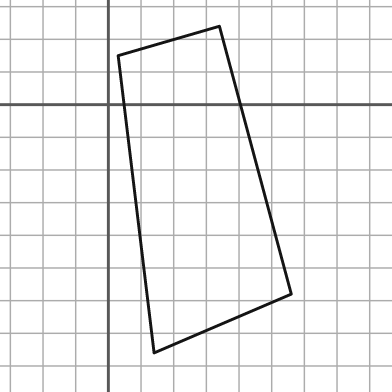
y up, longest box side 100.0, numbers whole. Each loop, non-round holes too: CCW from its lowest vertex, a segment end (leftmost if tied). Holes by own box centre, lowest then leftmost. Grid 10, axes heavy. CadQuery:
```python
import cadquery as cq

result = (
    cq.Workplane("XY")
    .moveTo(14.0, -76.0)
    .lineTo(56.0, -58.0)
    .lineTo(34.0, 24.0)
    .lineTo(3.0, 15.0)
    .close()
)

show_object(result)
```